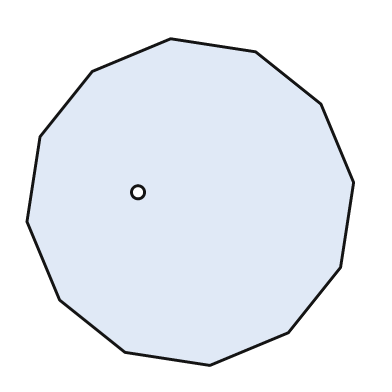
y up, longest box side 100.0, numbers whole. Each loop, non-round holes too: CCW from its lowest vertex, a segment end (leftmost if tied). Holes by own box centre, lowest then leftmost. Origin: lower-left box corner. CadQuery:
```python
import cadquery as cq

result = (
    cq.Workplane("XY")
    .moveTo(56.0, 0.0)
    .lineTo(80.0, 10.0)
    .lineTo(96.0, 30.0)
    .lineTo(100.0, 56.0)
    .lineTo(90.0, 80.0)
    .lineTo(70.0, 96.0)
    .lineTo(44.0, 100.0)
    .lineTo(20.0, 90.0)
    .lineTo(4.0, 70.0)
    .lineTo(0.0, 44.0)
    .lineTo(10.0, 20.0)
    .lineTo(30.0, 4.0)
    .close()
    .moveTo(34.0, 53.0)
    .circle(2.0)
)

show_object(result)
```